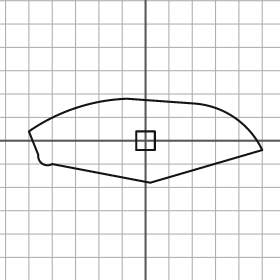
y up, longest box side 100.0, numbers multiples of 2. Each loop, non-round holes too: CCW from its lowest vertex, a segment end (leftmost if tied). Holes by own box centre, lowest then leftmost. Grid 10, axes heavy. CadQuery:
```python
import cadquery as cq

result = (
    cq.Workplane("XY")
    .moveTo(2.0, -18.0)
    .lineTo(50.0, -4.0)
    .threePointArc((38.0, 10.0), (20.0, 16.0))
    .lineTo(-8.0, 18.0)
    .threePointArc((-30.0, 14.0), (-50.0, 4.0))
    .lineTo(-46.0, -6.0)
    .threePointArc((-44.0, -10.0), (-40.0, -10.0))
    .close()
    .moveTo(-4.0, -4.0)
    .lineTo(4.0, -4.0)
    .lineTo(4.0, 4.0)
    .lineTo(-4.0, 4.0)
    .close()
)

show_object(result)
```